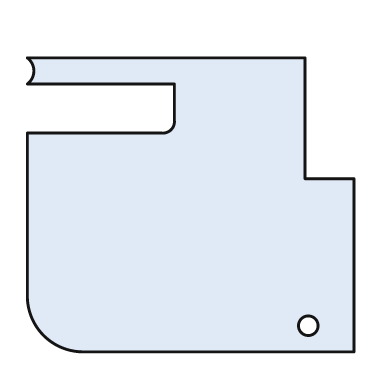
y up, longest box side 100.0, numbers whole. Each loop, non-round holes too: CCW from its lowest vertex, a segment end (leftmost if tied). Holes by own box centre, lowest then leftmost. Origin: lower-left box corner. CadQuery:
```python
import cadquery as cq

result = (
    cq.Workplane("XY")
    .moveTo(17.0, 0.0)
    .lineTo(100.0, 0.0)
    .lineTo(100.0, 53.0)
    .lineTo(85.0, 53.0)
    .lineTo(85.0, 90.0)
    .lineTo(0.0, 90.0)
    .threePointArc((2.0, 86.0), (0.0, 82.0))
    .lineTo(45.0, 82.0)
    .lineTo(45.0, 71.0)
    .threePointArc((44.0, 68.0), (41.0, 67.0))
    .lineTo(0.0, 67.0)
    .lineTo(0.0, 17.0)
    .threePointArc((5.0, 5.0), (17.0, 0.0))
    .close()
    .moveTo(86.0, 8.0)
    .circle(3.0)
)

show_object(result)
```